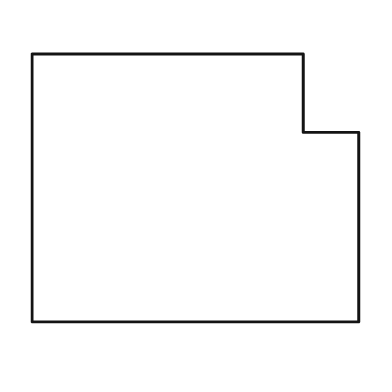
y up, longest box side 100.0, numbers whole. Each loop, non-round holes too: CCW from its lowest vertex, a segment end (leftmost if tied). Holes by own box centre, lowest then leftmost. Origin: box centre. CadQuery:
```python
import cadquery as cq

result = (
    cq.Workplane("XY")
    .moveTo(-50.0, -41.0)
    .lineTo(50.0, -41.0)
    .lineTo(50.0, 17.0)
    .lineTo(33.0, 17.0)
    .lineTo(33.0, 41.0)
    .lineTo(-50.0, 41.0)
    .close()
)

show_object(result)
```